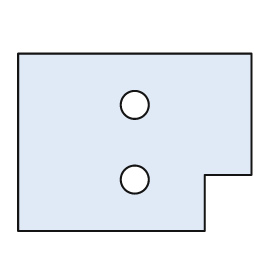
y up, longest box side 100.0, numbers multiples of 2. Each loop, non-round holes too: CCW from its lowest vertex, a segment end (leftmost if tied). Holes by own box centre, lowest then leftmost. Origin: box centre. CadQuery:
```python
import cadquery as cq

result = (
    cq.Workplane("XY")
    .moveTo(-50.0, -38.0)
    .lineTo(30.0, -38.0)
    .lineTo(30.0, -14.0)
    .lineTo(50.0, -14.0)
    .lineTo(50.0, 38.0)
    .lineTo(-50.0, 38.0)
    .close()
    .moveTo(0.0, -16.0)
    .circle(6.0)
    .moveTo(0.0, 16.0)
    .circle(6.0)
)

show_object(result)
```